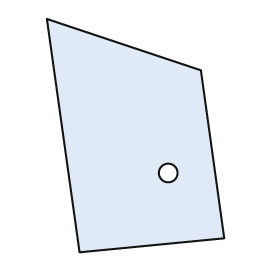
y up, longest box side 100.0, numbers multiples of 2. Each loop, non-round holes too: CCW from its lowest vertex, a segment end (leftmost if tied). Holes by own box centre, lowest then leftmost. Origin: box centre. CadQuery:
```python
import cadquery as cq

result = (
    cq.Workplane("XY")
    .moveTo(-24.0, -50.0)
    .lineTo(38.0, -44.0)
    .lineTo(28.0, 28.0)
    .lineTo(-38.0, 50.0)
    .close()
    .moveTo(14.0, -16.0)
    .circle(4.0)
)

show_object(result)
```